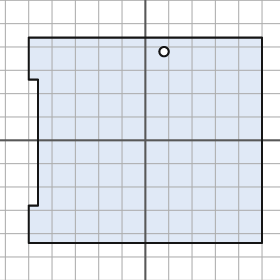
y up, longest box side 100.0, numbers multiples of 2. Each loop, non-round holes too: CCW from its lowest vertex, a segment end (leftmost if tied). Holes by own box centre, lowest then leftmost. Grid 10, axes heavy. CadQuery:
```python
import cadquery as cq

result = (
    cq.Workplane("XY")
    .moveTo(-50.0, -44.0)
    .lineTo(50.0, -44.0)
    .lineTo(50.0, 44.0)
    .lineTo(-50.0, 44.0)
    .lineTo(-50.0, 26.0)
    .lineTo(-46.0, 26.0)
    .lineTo(-46.0, -28.0)
    .lineTo(-50.0, -28.0)
    .close()
    .moveTo(8.0, 38.0)
    .circle(2.0)
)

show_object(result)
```